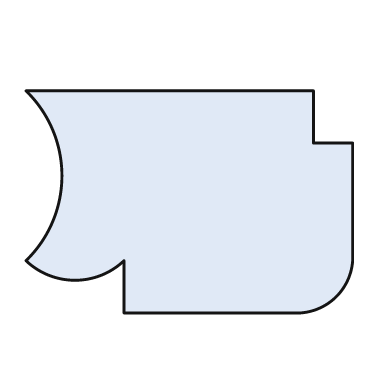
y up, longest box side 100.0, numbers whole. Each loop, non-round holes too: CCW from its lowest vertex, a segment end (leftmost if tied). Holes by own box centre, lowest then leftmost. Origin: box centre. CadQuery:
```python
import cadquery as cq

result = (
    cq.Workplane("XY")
    .moveTo(-20.0, -34.0)
    .lineTo(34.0, -34.0)
    .threePointArc((45.0, -29.0), (50.0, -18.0))
    .lineTo(50.0, 18.0)
    .lineTo(38.0, 18.0)
    .lineTo(38.0, 34.0)
    .lineTo(-50.0, 34.0)
    .threePointArc((-39.0, 8.0), (-50.0, -18.0))
    .threePointArc((-35.0, -24.0), (-20.0, -18.0))
    .close()
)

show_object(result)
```